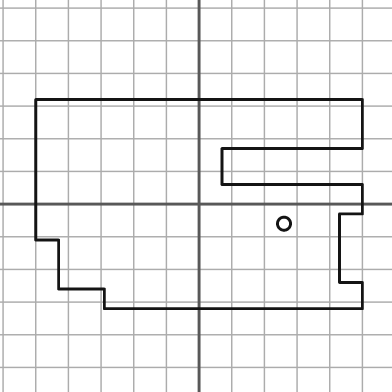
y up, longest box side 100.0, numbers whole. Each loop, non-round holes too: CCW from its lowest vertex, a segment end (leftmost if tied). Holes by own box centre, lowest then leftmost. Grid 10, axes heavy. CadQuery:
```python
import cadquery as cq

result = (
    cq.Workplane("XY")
    .moveTo(-29.0, -32.0)
    .lineTo(50.0, -32.0)
    .lineTo(50.0, -24.0)
    .lineTo(43.0, -24.0)
    .lineTo(43.0, -3.0)
    .lineTo(50.0, -3.0)
    .lineTo(50.0, 6.0)
    .lineTo(7.0, 6.0)
    .lineTo(7.0, 17.0)
    .lineTo(50.0, 17.0)
    .lineTo(50.0, 32.0)
    .lineTo(-50.0, 32.0)
    .lineTo(-50.0, -11.0)
    .lineTo(-43.0, -11.0)
    .lineTo(-43.0, -26.0)
    .lineTo(-29.0, -26.0)
    .close()
    .moveTo(26.0, -6.0)
    .circle(2.0)
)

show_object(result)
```